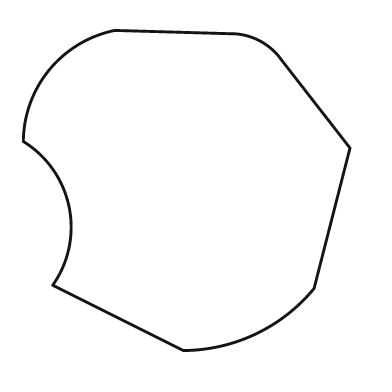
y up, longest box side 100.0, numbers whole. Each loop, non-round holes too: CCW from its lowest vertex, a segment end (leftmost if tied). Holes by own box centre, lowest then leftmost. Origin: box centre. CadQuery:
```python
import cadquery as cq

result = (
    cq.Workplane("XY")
    .moveTo(-1.0, -49.0)
    .threePointArc((21.0, -44.0), (39.0, -30.0))
    .lineTo(50.0, 13.0)
    .lineTo(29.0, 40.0)
    .threePointArc((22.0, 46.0), (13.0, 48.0))
    .lineTo(-22.0, 49.0)
    .threePointArc((-42.0, 37.0), (-50.0, 15.0))
    .threePointArc((-36.0, -5.0), (-41.0, -29.0))
    .close()
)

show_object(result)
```